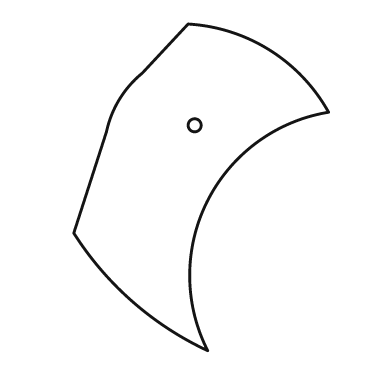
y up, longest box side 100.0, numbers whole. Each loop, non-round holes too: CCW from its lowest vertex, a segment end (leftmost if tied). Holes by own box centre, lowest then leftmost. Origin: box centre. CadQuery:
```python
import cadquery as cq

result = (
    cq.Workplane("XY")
    .moveTo(2.0, -50.0)
    .threePointArc((2.0, -4.0), (39.0, 23.0))
    .threePointArc((21.0, 42.0), (-4.0, 50.0))
    .lineTo(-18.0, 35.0)
    .threePointArc((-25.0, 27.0), (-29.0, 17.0))
    .lineTo(-39.0, -14.0)
    .threePointArc((-21.0, -35.0), (2.0, -50.0))
    .close()
    .moveTo(-2.0, 19.0)
    .circle(2.0)
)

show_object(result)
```